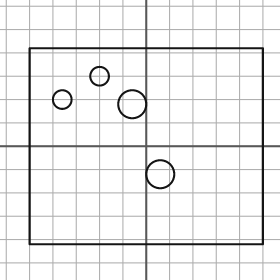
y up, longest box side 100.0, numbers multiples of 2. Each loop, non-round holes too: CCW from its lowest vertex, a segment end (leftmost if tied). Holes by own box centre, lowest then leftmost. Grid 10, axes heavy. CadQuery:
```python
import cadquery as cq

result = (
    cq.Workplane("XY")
    .moveTo(-50.0, -42.0)
    .lineTo(50.0, -42.0)
    .lineTo(50.0, 42.0)
    .lineTo(-50.0, 42.0)
    .close()
    .moveTo(6.0, -12.0)
    .circle(6.0)
    .moveTo(-6.0, 18.0)
    .circle(6.0)
    .moveTo(-36.0, 20.0)
    .circle(4.0)
    .moveTo(-20.0, 30.0)
    .circle(4.0)
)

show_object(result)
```